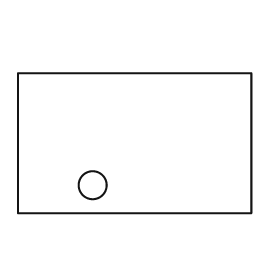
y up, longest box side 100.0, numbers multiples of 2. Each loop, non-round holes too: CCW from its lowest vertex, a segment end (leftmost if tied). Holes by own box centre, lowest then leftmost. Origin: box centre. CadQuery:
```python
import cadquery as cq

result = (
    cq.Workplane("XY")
    .moveTo(-50.0, -30.0)
    .lineTo(50.0, -30.0)
    .lineTo(50.0, 30.0)
    .lineTo(-50.0, 30.0)
    .close()
    .moveTo(-18.0, -18.0)
    .circle(6.0)
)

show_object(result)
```